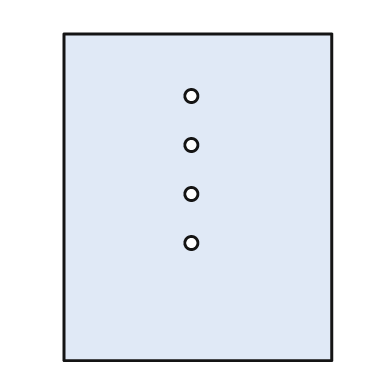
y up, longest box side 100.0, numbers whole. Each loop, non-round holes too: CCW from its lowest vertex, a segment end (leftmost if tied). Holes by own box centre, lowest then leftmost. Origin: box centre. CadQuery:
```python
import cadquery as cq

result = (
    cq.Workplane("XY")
    .moveTo(-41.0, -50.0)
    .lineTo(41.0, -50.0)
    .lineTo(41.0, 50.0)
    .lineTo(-41.0, 50.0)
    .close()
    .moveTo(-2.0, -14.0)
    .circle(2.0)
    .moveTo(-2.0, 1.0)
    .circle(2.0)
    .moveTo(-2.0, 16.0)
    .circle(2.0)
    .moveTo(-2.0, 31.0)
    .circle(2.0)
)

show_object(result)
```